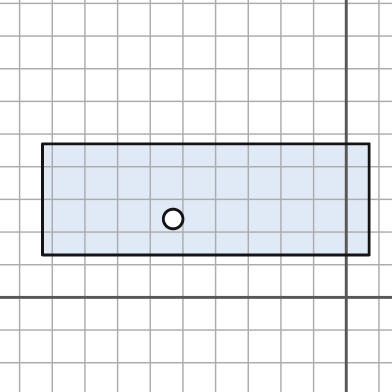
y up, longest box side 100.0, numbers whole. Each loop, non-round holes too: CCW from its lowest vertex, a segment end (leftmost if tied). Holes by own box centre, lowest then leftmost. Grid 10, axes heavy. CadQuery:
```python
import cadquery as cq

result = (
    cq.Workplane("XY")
    .moveTo(-93.0, 13.0)
    .lineTo(7.0, 13.0)
    .lineTo(7.0, 47.0)
    .lineTo(-93.0, 47.0)
    .close()
    .moveTo(-53.0, 24.0)
    .circle(3.0)
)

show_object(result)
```